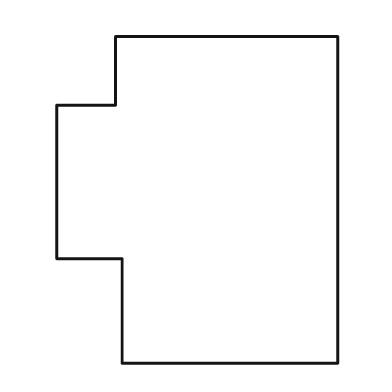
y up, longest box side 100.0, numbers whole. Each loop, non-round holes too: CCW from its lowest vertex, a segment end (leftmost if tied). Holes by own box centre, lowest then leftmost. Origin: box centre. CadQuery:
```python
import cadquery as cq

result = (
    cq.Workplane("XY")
    .moveTo(-23.0, -50.0)
    .lineTo(43.0, -50.0)
    .lineTo(43.0, 50.0)
    .lineTo(-25.0, 50.0)
    .lineTo(-25.0, 29.0)
    .lineTo(-43.0, 29.0)
    .lineTo(-43.0, -18.0)
    .lineTo(-23.0, -18.0)
    .close()
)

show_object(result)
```